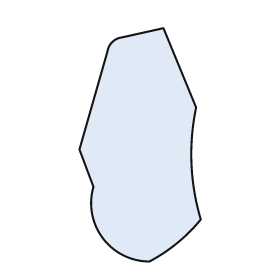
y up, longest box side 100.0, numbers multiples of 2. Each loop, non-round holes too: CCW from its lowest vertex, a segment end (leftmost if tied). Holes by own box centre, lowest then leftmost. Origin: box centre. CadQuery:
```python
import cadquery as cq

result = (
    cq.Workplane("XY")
    .moveTo(4.0, -50.0)
    .threePointArc((16.0, -42.0), (26.0, -32.0))
    .threePointArc((22.0, -8.0), (24.0, 16.0))
    .lineTo(10.0, 50.0)
    .lineTo(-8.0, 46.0)
    .threePointArc((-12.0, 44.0), (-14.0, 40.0))
    .lineTo(-26.0, -2.0)
    .lineTo(-20.0, -18.0)
    .threePointArc((-16.0, -40.0), (4.0, -50.0))
    .close()
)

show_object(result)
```